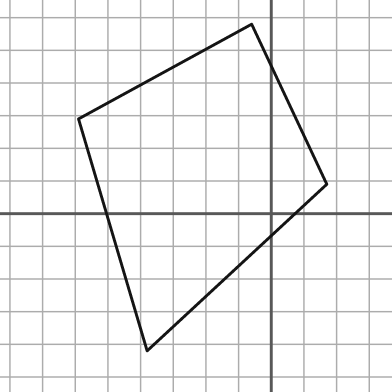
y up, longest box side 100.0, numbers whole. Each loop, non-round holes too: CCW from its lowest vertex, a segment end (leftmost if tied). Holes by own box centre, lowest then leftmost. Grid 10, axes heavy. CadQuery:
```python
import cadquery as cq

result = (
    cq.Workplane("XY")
    .moveTo(-38.0, -42.0)
    .lineTo(17.0, 9.0)
    .lineTo(-6.0, 58.0)
    .lineTo(-59.0, 29.0)
    .close()
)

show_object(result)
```